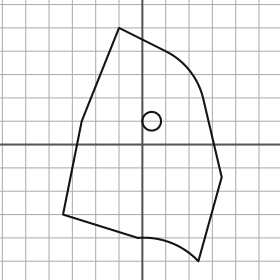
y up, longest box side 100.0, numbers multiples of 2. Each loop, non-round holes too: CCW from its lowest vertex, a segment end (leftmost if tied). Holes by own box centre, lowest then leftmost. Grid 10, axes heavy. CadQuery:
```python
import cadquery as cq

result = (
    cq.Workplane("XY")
    .moveTo(24.0, -50.0)
    .lineTo(34.0, -14.0)
    .lineTo(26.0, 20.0)
    .threePointArc((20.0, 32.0), (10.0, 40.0))
    .lineTo(-10.0, 50.0)
    .lineTo(-26.0, 10.0)
    .lineTo(-34.0, -30.0)
    .lineTo(-2.0, -40.0)
    .threePointArc((12.0, -42.0), (24.0, -50.0))
    .close()
    .moveTo(4.0, 10.0)
    .circle(4.0)
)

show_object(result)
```